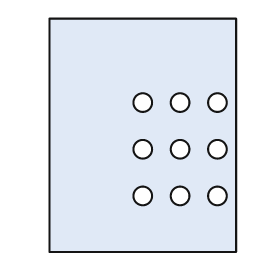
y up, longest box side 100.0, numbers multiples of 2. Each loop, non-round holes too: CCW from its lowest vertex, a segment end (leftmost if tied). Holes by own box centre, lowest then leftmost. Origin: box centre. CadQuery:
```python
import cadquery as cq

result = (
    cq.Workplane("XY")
    .moveTo(-40.0, -50.0)
    .lineTo(40.0, -50.0)
    .lineTo(40.0, 50.0)
    .lineTo(-40.0, 50.0)
    .close()
    .moveTo(0.0, -26.0)
    .circle(4.0)
    .moveTo(16.0, -26.0)
    .circle(4.0)
    .moveTo(32.0, -26.0)
    .circle(4.0)
    .moveTo(0.0, -6.0)
    .circle(4.0)
    .moveTo(16.0, -6.0)
    .circle(4.0)
    .moveTo(32.0, -6.0)
    .circle(4.0)
    .moveTo(0.0, 14.0)
    .circle(4.0)
    .moveTo(16.0, 14.0)
    .circle(4.0)
    .moveTo(32.0, 14.0)
    .circle(4.0)
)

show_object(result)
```